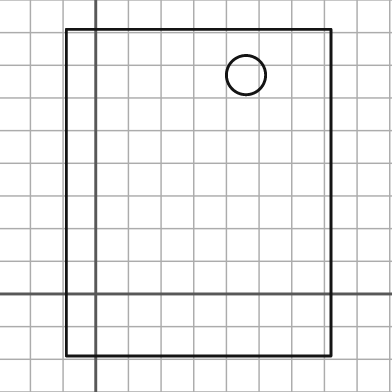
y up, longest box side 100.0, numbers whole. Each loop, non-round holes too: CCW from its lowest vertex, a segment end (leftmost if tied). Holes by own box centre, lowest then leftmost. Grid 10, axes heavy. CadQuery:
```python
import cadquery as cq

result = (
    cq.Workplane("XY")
    .moveTo(-9.0, -19.0)
    .lineTo(72.0, -19.0)
    .lineTo(72.0, 81.0)
    .lineTo(-9.0, 81.0)
    .close()
    .moveTo(46.0, 67.0)
    .circle(6.0)
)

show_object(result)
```